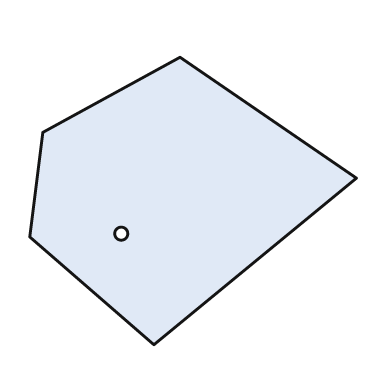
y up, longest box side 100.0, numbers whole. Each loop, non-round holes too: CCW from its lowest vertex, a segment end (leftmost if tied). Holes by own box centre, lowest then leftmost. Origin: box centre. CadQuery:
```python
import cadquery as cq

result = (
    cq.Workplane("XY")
    .moveTo(-12.0, -44.0)
    .lineTo(50.0, 7.0)
    .lineTo(-4.0, 44.0)
    .lineTo(-46.0, 21.0)
    .lineTo(-50.0, -11.0)
    .close()
    .moveTo(-22.0, -10.0)
    .circle(2.0)
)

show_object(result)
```